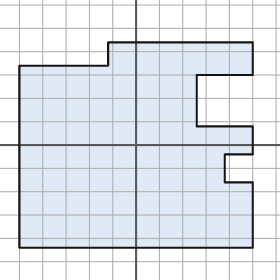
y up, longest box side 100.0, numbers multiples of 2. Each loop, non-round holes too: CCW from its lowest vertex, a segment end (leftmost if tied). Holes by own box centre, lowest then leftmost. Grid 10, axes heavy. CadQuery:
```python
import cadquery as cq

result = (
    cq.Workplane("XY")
    .moveTo(-50.0, -44.0)
    .lineTo(50.0, -44.0)
    .lineTo(50.0, -16.0)
    .lineTo(38.0, -16.0)
    .lineTo(38.0, -4.0)
    .lineTo(50.0, -4.0)
    .lineTo(50.0, 8.0)
    .lineTo(26.0, 8.0)
    .lineTo(26.0, 30.0)
    .lineTo(50.0, 30.0)
    .lineTo(50.0, 44.0)
    .lineTo(-12.0, 44.0)
    .lineTo(-12.0, 34.0)
    .lineTo(-50.0, 34.0)
    .close()
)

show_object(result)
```